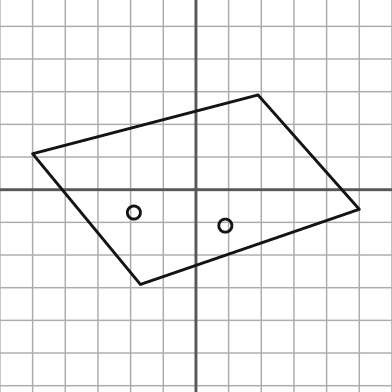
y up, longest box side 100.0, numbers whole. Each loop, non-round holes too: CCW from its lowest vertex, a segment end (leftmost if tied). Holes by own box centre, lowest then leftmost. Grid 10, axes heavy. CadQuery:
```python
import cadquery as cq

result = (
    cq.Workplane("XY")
    .moveTo(-17.0, -29.0)
    .lineTo(50.0, -6.0)
    .lineTo(19.0, 29.0)
    .lineTo(-50.0, 11.0)
    .close()
    .moveTo(9.0, -11.0)
    .circle(2.0)
    .moveTo(-19.0, -7.0)
    .circle(2.0)
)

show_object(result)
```